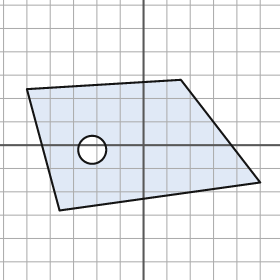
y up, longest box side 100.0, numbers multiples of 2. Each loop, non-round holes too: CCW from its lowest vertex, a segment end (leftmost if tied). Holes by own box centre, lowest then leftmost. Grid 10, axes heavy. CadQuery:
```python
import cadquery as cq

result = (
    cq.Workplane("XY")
    .moveTo(-36.0, -28.0)
    .lineTo(50.0, -16.0)
    .lineTo(16.0, 28.0)
    .lineTo(-50.0, 24.0)
    .close()
    .moveTo(-22.0, -2.0)
    .circle(6.0)
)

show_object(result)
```